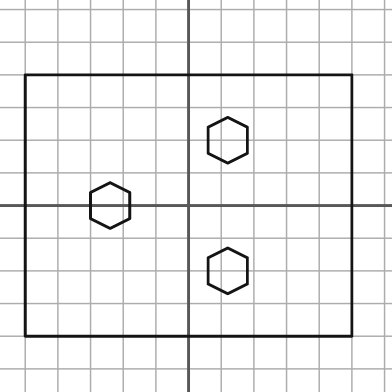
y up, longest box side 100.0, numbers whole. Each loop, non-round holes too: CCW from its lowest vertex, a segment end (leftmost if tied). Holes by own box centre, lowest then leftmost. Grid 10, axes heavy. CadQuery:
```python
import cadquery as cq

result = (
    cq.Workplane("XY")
    .moveTo(-50.0, -40.0)
    .lineTo(50.0, -40.0)
    .lineTo(50.0, 40.0)
    .lineTo(-50.0, 40.0)
    .close()
    .moveTo(12.0, -27.0)
    .lineTo(18.0, -24.0)
    .lineTo(18.0, -16.0)
    .lineTo(12.0, -13.0)
    .lineTo(6.0, -16.0)
    .lineTo(6.0, -24.0)
    .close()
    .moveTo(-24.0, -7.0)
    .lineTo(-18.0, -4.0)
    .lineTo(-18.0, 4.0)
    .lineTo(-24.0, 7.0)
    .lineTo(-30.0, 4.0)
    .lineTo(-30.0, -4.0)
    .close()
    .moveTo(12.0, 13.0)
    .lineTo(18.0, 16.0)
    .lineTo(18.0, 24.0)
    .lineTo(12.0, 27.0)
    .lineTo(6.0, 24.0)
    .lineTo(6.0, 16.0)
    .close()
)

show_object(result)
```